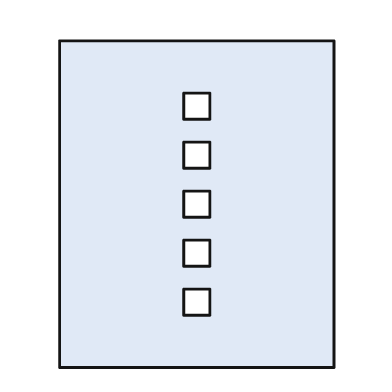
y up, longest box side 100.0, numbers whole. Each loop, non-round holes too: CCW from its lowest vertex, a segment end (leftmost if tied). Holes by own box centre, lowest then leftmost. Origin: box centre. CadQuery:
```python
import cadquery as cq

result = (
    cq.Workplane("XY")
    .moveTo(-42.0, -50.0)
    .lineTo(42.0, -50.0)
    .lineTo(42.0, 50.0)
    .lineTo(-42.0, 50.0)
    .close()
    .moveTo(-4.0, -34.0)
    .lineTo(4.0, -34.0)
    .lineTo(4.0, -26.0)
    .lineTo(-4.0, -26.0)
    .close()
    .moveTo(-4.0, -19.0)
    .lineTo(4.0, -19.0)
    .lineTo(4.0, -11.0)
    .lineTo(-4.0, -11.0)
    .close()
    .moveTo(-4.0, -4.0)
    .lineTo(4.0, -4.0)
    .lineTo(4.0, 4.0)
    .lineTo(-4.0, 4.0)
    .close()
    .moveTo(-4.0, 11.0)
    .lineTo(4.0, 11.0)
    .lineTo(4.0, 19.0)
    .lineTo(-4.0, 19.0)
    .close()
    .moveTo(-4.0, 26.0)
    .lineTo(4.0, 26.0)
    .lineTo(4.0, 34.0)
    .lineTo(-4.0, 34.0)
    .close()
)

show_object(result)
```